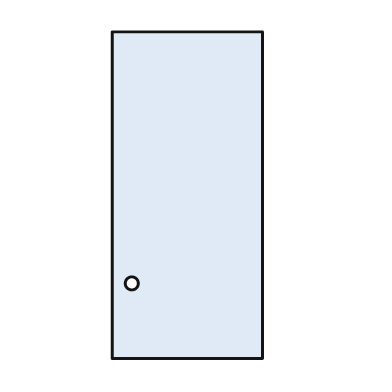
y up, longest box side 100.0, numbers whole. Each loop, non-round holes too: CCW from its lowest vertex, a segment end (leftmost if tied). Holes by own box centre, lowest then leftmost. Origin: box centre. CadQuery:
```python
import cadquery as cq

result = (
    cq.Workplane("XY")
    .moveTo(-23.0, -50.0)
    .lineTo(23.0, -50.0)
    .lineTo(23.0, 50.0)
    .lineTo(-23.0, 50.0)
    .close()
    .moveTo(-17.0, -27.0)
    .circle(2.0)
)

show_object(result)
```